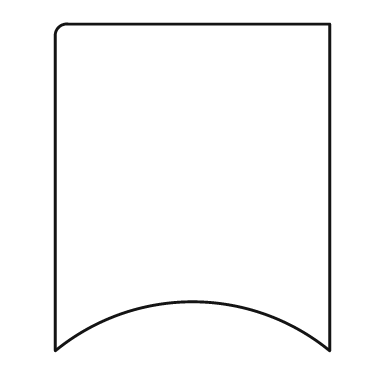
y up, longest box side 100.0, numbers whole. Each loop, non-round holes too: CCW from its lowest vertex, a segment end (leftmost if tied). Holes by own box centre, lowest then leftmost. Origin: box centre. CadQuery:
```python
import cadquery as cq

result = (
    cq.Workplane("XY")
    .moveTo(-42.0, -50.0)
    .threePointArc((0.0, -35.0), (42.0, -50.0))
    .lineTo(42.0, 50.0)
    .lineTo(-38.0, 50.0)
    .threePointArc((-41.0, 49.0), (-42.0, 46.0))
    .close()
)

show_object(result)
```